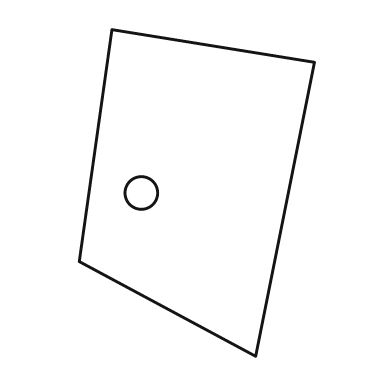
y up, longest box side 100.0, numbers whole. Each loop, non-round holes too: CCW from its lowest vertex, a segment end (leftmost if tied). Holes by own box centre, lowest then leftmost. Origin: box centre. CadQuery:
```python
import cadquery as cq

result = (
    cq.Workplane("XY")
    .moveTo(18.0, -50.0)
    .lineTo(36.0, 40.0)
    .lineTo(-26.0, 50.0)
    .lineTo(-36.0, -21.0)
    .close()
    .moveTo(-17.0, 0.0)
    .circle(5.0)
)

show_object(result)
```